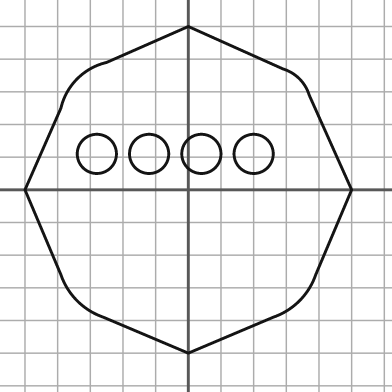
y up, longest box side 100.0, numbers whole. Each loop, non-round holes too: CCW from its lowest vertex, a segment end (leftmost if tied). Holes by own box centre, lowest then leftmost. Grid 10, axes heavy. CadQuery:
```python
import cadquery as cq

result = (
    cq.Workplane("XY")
    .moveTo(0.0, -50.0)
    .lineTo(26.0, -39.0)
    .threePointArc((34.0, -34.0), (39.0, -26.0))
    .lineTo(50.0, 0.0)
    .lineTo(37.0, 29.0)
    .threePointArc((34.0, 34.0), (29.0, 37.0))
    .lineTo(0.0, 50.0)
    .lineTo(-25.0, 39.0)
    .threePointArc((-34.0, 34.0), (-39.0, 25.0))
    .lineTo(-50.0, 0.0)
    .lineTo(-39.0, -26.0)
    .threePointArc((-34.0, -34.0), (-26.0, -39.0))
    .close()
    .moveTo(-28.0, 11.0)
    .circle(6.0)
    .moveTo(-12.0, 11.0)
    .circle(6.0)
    .moveTo(4.0, 11.0)
    .circle(6.0)
    .moveTo(20.0, 11.0)
    .circle(6.0)
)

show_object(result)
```